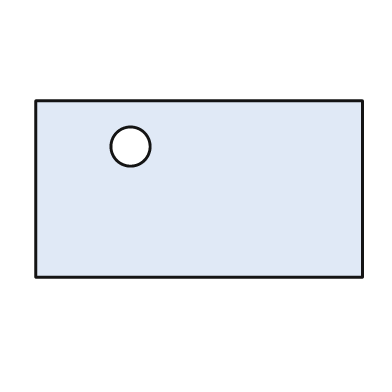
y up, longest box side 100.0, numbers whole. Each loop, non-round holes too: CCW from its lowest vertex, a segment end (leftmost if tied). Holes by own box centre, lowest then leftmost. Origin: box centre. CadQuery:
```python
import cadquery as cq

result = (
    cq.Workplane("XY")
    .moveTo(-50.0, -27.0)
    .lineTo(50.0, -27.0)
    .lineTo(50.0, 27.0)
    .lineTo(-50.0, 27.0)
    .close()
    .moveTo(-21.0, 13.0)
    .circle(6.0)
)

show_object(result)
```